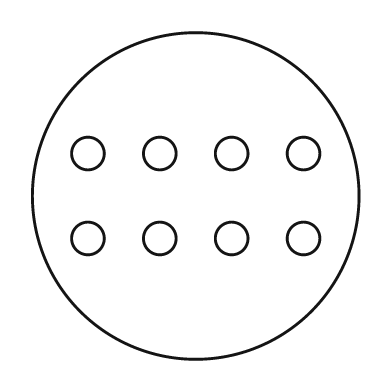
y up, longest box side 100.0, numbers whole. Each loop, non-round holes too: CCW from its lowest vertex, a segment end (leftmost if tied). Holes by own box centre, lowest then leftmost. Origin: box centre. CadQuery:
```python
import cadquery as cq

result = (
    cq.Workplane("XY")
    .moveTo(0.0, 0.0)
    .circle(50.0)
    .moveTo(-33.0, -13.0)
    .circle(5.0)
    .moveTo(-11.0, -13.0)
    .circle(5.0)
    .moveTo(11.0, -13.0)
    .circle(5.0)
    .moveTo(33.0, -13.0)
    .circle(5.0)
    .moveTo(-33.0, 13.0)
    .circle(5.0)
    .moveTo(-11.0, 13.0)
    .circle(5.0)
    .moveTo(11.0, 13.0)
    .circle(5.0)
    .moveTo(33.0, 13.0)
    .circle(5.0)
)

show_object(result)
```